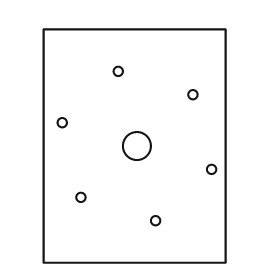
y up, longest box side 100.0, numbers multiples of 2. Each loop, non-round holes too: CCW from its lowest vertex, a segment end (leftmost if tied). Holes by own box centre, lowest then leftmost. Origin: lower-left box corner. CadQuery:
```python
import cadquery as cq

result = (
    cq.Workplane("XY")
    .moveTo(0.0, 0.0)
    .lineTo(78.0, 0.0)
    .lineTo(78.0, 100.0)
    .lineTo(0.0, 100.0)
    .close()
    .moveTo(48.0, 18.0)
    .circle(2.0)
    .moveTo(16.0, 28.0)
    .circle(2.0)
    .moveTo(72.0, 40.0)
    .circle(2.0)
    .moveTo(40.0, 50.0)
    .circle(6.0)
    .moveTo(8.0, 60.0)
    .circle(2.0)
    .moveTo(64.0, 72.0)
    .circle(2.0)
    .moveTo(32.0, 82.0)
    .circle(2.0)
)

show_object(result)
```